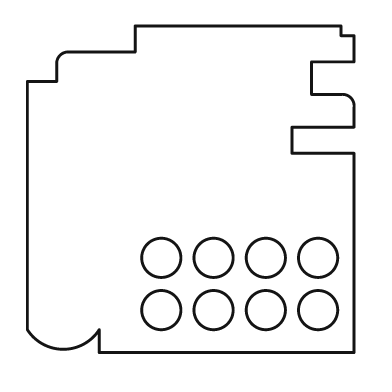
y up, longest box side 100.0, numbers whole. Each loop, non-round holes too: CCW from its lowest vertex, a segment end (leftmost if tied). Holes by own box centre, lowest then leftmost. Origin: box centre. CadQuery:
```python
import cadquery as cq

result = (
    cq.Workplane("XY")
    .moveTo(-28.0, -50.0)
    .lineTo(50.0, -50.0)
    .lineTo(50.0, 11.0)
    .lineTo(31.0, 11.0)
    .lineTo(31.0, 19.0)
    .lineTo(50.0, 19.0)
    .lineTo(50.0, 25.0)
    .threePointArc((49.0, 28.0), (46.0, 29.0))
    .lineTo(37.0, 29.0)
    .lineTo(37.0, 39.0)
    .lineTo(50.0, 39.0)
    .lineTo(50.0, 47.0)
    .lineTo(46.0, 47.0)
    .lineTo(46.0, 50.0)
    .lineTo(-17.0, 50.0)
    .lineTo(-17.0, 42.0)
    .lineTo(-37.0, 42.0)
    .threePointArc((-40.0, 41.0), (-41.0, 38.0))
    .lineTo(-41.0, 33.0)
    .lineTo(-50.0, 33.0)
    .lineTo(-50.0, -43.0)
    .threePointArc((-39.0, -49.0), (-28.0, -43.0))
    .close()
    .moveTo(-9.0, -37.0)
    .circle(6.0)
    .moveTo(7.0, -37.0)
    .circle(6.0)
    .moveTo(23.0, -37.0)
    .circle(6.0)
    .moveTo(39.0, -37.0)
    .circle(6.0)
    .moveTo(-9.0, -21.0)
    .circle(6.0)
    .moveTo(7.0, -21.0)
    .circle(6.0)
    .moveTo(23.0, -21.0)
    .circle(6.0)
    .moveTo(39.0, -21.0)
    .circle(6.0)
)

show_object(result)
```